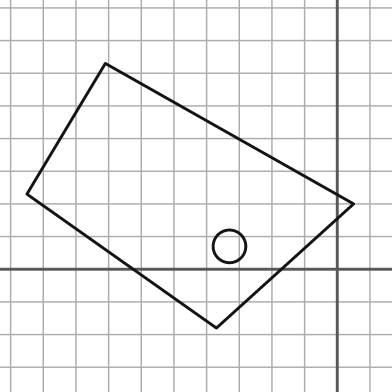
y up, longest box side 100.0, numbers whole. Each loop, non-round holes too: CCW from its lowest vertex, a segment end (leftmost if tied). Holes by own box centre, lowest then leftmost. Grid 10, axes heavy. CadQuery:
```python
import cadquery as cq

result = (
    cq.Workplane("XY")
    .moveTo(-37.0, -18.0)
    .lineTo(5.0, 20.0)
    .lineTo(-71.0, 63.0)
    .lineTo(-95.0, 23.0)
    .close()
    .moveTo(-33.0, 7.0)
    .circle(5.0)
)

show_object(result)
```